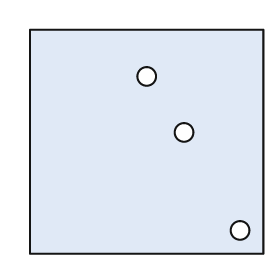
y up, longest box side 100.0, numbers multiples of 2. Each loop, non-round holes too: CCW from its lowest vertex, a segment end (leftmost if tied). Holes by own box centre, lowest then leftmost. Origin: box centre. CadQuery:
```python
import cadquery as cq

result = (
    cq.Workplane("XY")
    .moveTo(-50.0, -48.0)
    .lineTo(50.0, -48.0)
    .lineTo(50.0, 48.0)
    .lineTo(-50.0, 48.0)
    .close()
    .moveTo(40.0, -38.0)
    .circle(4.0)
    .moveTo(16.0, 4.0)
    .circle(4.0)
    .moveTo(0.0, 28.0)
    .circle(4.0)
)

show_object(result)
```